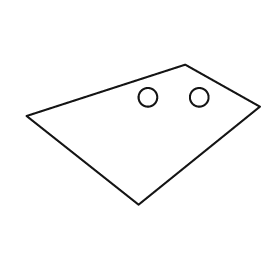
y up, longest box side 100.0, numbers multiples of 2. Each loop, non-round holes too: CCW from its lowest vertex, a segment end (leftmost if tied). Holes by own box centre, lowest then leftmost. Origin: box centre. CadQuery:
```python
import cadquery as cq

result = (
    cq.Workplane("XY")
    .moveTo(-2.0, -30.0)
    .lineTo(50.0, 12.0)
    .lineTo(18.0, 30.0)
    .lineTo(-50.0, 8.0)
    .close()
    .moveTo(2.0, 16.0)
    .circle(4.0)
    .moveTo(24.0, 16.0)
    .circle(4.0)
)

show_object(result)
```